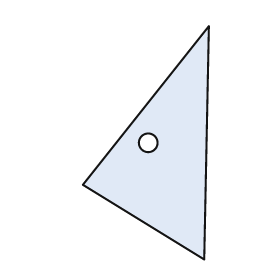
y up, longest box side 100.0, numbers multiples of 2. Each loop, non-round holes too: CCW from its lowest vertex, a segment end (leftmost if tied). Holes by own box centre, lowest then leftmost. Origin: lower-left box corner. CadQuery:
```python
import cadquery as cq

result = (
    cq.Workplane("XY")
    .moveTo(52.0, 0.0)
    .lineTo(54.0, 100.0)
    .lineTo(0.0, 32.0)
    .close()
    .moveTo(28.0, 50.0)
    .circle(4.0)
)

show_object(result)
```